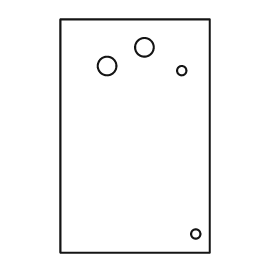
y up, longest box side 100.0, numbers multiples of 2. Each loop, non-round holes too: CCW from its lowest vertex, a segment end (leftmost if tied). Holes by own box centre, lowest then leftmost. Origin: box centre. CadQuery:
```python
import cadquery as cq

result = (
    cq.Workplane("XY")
    .moveTo(-32.0, -50.0)
    .lineTo(32.0, -50.0)
    .lineTo(32.0, 50.0)
    .lineTo(-32.0, 50.0)
    .close()
    .moveTo(26.0, -42.0)
    .circle(2.0)
    .moveTo(20.0, 28.0)
    .circle(2.0)
    .moveTo(-12.0, 30.0)
    .circle(4.0)
    .moveTo(4.0, 38.0)
    .circle(4.0)
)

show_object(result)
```